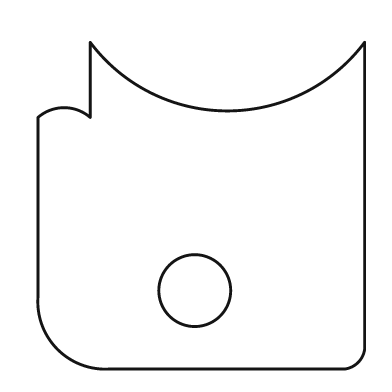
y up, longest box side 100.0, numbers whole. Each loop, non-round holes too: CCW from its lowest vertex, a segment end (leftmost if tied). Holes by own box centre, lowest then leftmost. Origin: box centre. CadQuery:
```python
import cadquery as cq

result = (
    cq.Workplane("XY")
    .moveTo(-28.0, -50.0)
    .lineTo(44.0, -50.0)
    .threePointArc((48.0, -48.0), (50.0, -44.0))
    .lineTo(50.0, 50.0)
    .threePointArc((8.0, 29.0), (-34.0, 50.0))
    .lineTo(-34.0, 27.0)
    .threePointArc((-42.0, 30.0), (-50.0, 27.0))
    .lineTo(-50.0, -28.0)
    .threePointArc((-44.0, -44.0), (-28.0, -50.0))
    .close()
    .moveTo(-2.0, -26.0)
    .circle(11.0)
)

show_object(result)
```